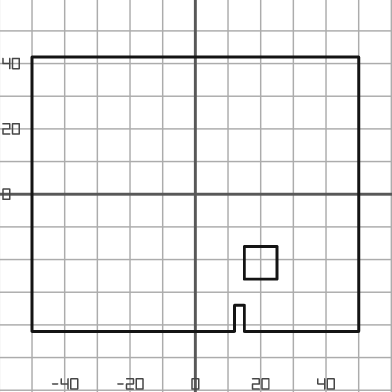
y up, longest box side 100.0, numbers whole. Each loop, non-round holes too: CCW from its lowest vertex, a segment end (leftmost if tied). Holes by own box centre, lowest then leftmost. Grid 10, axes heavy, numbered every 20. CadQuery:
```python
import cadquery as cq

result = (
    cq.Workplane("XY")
    .moveTo(-50.0, -42.0)
    .lineTo(12.0, -42.0)
    .lineTo(12.0, -34.0)
    .lineTo(15.0, -34.0)
    .lineTo(15.0, -42.0)
    .lineTo(50.0, -42.0)
    .lineTo(50.0, 42.0)
    .lineTo(-50.0, 42.0)
    .close()
    .moveTo(15.0, -26.0)
    .lineTo(25.0, -26.0)
    .lineTo(25.0, -16.0)
    .lineTo(15.0, -16.0)
    .close()
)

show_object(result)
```